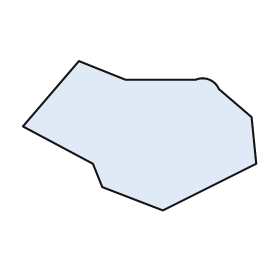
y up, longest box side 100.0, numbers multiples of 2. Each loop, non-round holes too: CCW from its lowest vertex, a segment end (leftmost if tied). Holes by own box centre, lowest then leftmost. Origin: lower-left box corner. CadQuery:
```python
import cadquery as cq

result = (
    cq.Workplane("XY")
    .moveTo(60.0, 0.0)
    .lineTo(100.0, 20.0)
    .lineTo(98.0, 40.0)
    .lineTo(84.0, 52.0)
    .threePointArc((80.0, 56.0), (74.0, 56.0))
    .lineTo(44.0, 56.0)
    .lineTo(24.0, 64.0)
    .lineTo(0.0, 36.0)
    .lineTo(30.0, 20.0)
    .lineTo(34.0, 10.0)
    .close()
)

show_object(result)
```